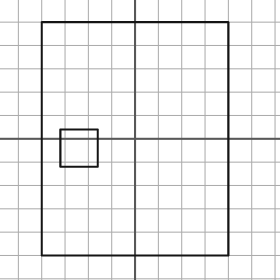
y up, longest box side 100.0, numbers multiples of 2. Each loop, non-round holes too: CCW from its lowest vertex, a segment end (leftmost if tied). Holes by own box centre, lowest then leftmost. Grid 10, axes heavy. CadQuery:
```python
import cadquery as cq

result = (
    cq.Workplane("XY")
    .moveTo(-40.0, -50.0)
    .lineTo(40.0, -50.0)
    .lineTo(40.0, 50.0)
    .lineTo(-40.0, 50.0)
    .close()
    .moveTo(-32.0, -12.0)
    .lineTo(-16.0, -12.0)
    .lineTo(-16.0, 4.0)
    .lineTo(-32.0, 4.0)
    .close()
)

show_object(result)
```